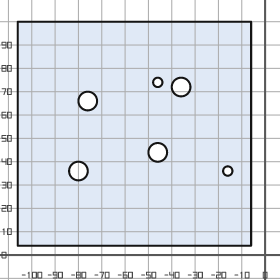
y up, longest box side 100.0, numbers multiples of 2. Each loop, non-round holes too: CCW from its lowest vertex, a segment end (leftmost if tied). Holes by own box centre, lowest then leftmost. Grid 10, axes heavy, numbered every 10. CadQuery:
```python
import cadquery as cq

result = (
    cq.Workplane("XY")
    .moveTo(-106.0, 4.0)
    .lineTo(-6.0, 4.0)
    .lineTo(-6.0, 100.0)
    .lineTo(-106.0, 100.0)
    .close()
    .moveTo(-80.0, 36.0)
    .circle(4.0)
    .moveTo(-16.0, 36.0)
    .circle(2.0)
    .moveTo(-46.0, 44.0)
    .circle(4.0)
    .moveTo(-76.0, 66.0)
    .circle(4.0)
    .moveTo(-36.0, 72.0)
    .circle(4.0)
    .moveTo(-46.0, 74.0)
    .circle(2.0)
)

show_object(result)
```